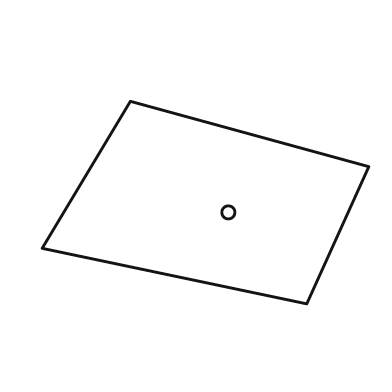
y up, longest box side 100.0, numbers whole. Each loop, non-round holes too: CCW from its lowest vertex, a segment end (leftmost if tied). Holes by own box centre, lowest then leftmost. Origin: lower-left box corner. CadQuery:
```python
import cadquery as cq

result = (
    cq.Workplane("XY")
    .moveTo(81.0, 0.0)
    .lineTo(100.0, 42.0)
    .lineTo(27.0, 62.0)
    .lineTo(0.0, 17.0)
    .close()
    .moveTo(57.0, 28.0)
    .circle(2.0)
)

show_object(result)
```